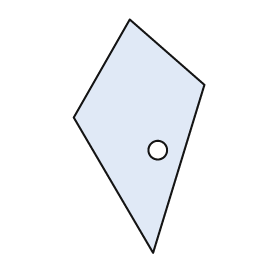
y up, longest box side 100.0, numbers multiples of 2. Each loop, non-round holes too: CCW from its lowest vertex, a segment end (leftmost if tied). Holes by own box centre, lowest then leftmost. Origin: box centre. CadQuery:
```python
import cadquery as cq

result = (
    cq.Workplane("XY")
    .moveTo(6.0, -50.0)
    .lineTo(28.0, 22.0)
    .lineTo(-4.0, 50.0)
    .lineTo(-28.0, 8.0)
    .close()
    .moveTo(8.0, -6.0)
    .circle(4.0)
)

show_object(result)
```